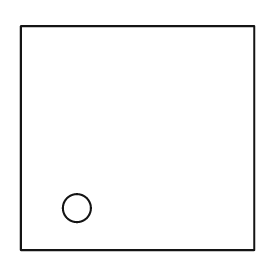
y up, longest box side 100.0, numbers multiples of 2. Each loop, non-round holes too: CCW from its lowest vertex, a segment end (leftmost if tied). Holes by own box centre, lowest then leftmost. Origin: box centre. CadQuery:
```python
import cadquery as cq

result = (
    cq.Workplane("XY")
    .moveTo(-50.0, -48.0)
    .lineTo(50.0, -48.0)
    .lineTo(50.0, 48.0)
    .lineTo(-50.0, 48.0)
    .close()
    .moveTo(-26.0, -30.0)
    .circle(6.0)
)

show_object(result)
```